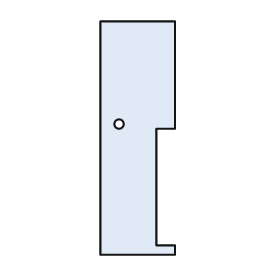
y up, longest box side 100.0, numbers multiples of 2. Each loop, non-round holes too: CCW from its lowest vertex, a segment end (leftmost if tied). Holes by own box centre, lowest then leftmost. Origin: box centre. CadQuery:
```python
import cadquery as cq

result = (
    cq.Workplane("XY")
    .moveTo(-16.0, -50.0)
    .lineTo(16.0, -50.0)
    .lineTo(16.0, -46.0)
    .lineTo(8.0, -46.0)
    .lineTo(8.0, 4.0)
    .lineTo(16.0, 4.0)
    .lineTo(16.0, 50.0)
    .lineTo(-16.0, 50.0)
    .close()
    .moveTo(-8.0, 6.0)
    .circle(2.0)
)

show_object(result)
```